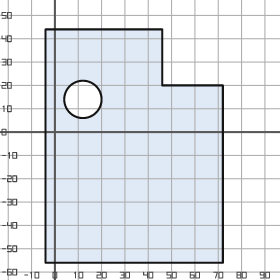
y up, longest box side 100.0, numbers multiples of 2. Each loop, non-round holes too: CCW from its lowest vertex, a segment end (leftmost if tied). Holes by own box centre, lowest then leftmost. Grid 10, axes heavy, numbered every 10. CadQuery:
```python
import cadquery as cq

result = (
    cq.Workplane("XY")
    .moveTo(-4.0, -56.0)
    .lineTo(72.0, -56.0)
    .lineTo(72.0, 20.0)
    .lineTo(46.0, 20.0)
    .lineTo(46.0, 44.0)
    .lineTo(-4.0, 44.0)
    .close()
    .moveTo(12.0, 14.0)
    .circle(8.0)
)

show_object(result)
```